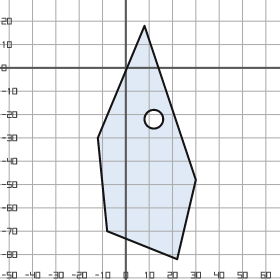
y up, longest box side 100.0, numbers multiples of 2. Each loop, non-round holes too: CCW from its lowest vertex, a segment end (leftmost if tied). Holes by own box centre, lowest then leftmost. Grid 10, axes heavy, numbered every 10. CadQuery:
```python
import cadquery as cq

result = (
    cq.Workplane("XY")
    .moveTo(22.0, -82.0)
    .lineTo(30.0, -48.0)
    .lineTo(8.0, 18.0)
    .lineTo(-12.0, -30.0)
    .lineTo(-8.0, -70.0)
    .close()
    .moveTo(12.0, -22.0)
    .circle(4.0)
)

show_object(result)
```